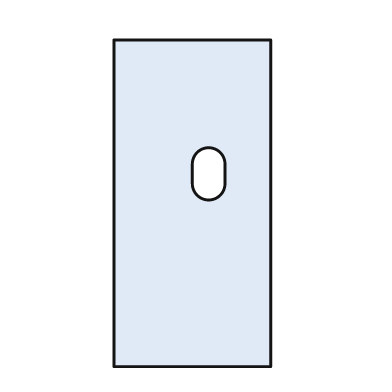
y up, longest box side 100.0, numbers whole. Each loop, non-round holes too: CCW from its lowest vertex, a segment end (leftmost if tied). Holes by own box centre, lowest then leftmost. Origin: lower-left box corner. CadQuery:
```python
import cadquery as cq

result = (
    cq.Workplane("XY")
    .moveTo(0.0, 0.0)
    .lineTo(48.0, 0.0)
    .lineTo(48.0, 100.0)
    .lineTo(0.0, 100.0)
    .close()
    .moveTo(24.0, 56.0)
    .threePointArc((29.0, 51.0), (34.0, 56.0))
    .lineTo(34.0, 62.0)
    .threePointArc((29.0, 67.0), (24.0, 62.0))
    .close()
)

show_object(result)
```